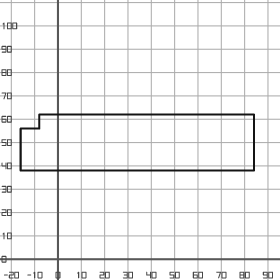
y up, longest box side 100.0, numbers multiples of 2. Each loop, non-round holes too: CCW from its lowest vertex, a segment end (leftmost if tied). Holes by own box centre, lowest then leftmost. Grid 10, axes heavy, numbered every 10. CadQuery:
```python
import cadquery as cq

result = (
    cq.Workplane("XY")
    .moveTo(-16.0, 38.0)
    .lineTo(84.0, 38.0)
    .lineTo(84.0, 62.0)
    .lineTo(-8.0, 62.0)
    .lineTo(-8.0, 56.0)
    .lineTo(-16.0, 56.0)
    .close()
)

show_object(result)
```